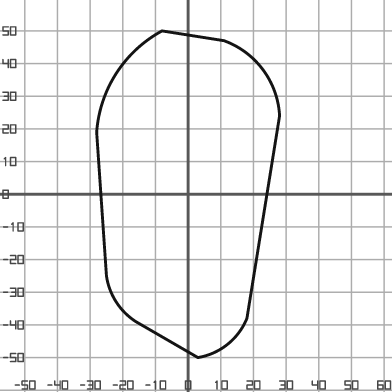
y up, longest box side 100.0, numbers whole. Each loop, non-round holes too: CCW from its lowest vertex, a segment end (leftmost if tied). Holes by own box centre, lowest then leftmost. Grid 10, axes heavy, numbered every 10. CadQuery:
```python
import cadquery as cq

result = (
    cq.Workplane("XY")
    .moveTo(3.0, -50.0)
    .threePointArc((12.0, -46.0), (18.0, -38.0))
    .lineTo(28.0, 24.0)
    .threePointArc((23.0, 38.0), (11.0, 47.0))
    .lineTo(-8.0, 50.0)
    .threePointArc((-22.0, 37.0), (-28.0, 19.0))
    .lineTo(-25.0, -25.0)
    .threePointArc((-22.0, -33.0), (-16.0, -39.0))
    .close()
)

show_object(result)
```